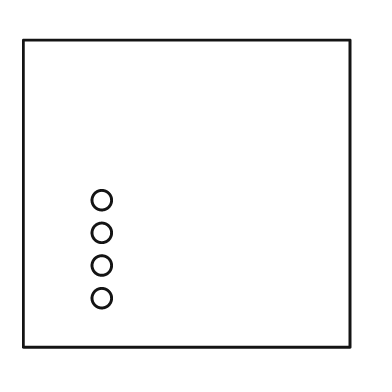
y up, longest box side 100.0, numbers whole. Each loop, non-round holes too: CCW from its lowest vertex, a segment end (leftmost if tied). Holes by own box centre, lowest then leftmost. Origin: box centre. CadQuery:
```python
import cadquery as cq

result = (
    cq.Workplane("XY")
    .moveTo(-50.0, -47.0)
    .lineTo(50.0, -47.0)
    .lineTo(50.0, 47.0)
    .lineTo(-50.0, 47.0)
    .close()
    .moveTo(-26.0, -32.0)
    .circle(3.0)
    .moveTo(-26.0, -22.0)
    .circle(3.0)
    .moveTo(-26.0, -12.0)
    .circle(3.0)
    .moveTo(-26.0, -2.0)
    .circle(3.0)
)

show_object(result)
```